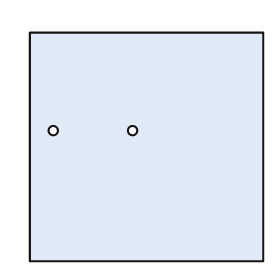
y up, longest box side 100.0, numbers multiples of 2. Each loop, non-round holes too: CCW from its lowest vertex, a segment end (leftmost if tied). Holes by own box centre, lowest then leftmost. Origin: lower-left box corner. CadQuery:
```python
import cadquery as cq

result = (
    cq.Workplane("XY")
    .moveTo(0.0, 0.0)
    .lineTo(100.0, 0.0)
    .lineTo(100.0, 98.0)
    .lineTo(0.0, 98.0)
    .close()
    .moveTo(10.0, 56.0)
    .circle(2.0)
    .moveTo(44.0, 56.0)
    .circle(2.0)
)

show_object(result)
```